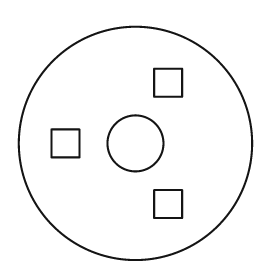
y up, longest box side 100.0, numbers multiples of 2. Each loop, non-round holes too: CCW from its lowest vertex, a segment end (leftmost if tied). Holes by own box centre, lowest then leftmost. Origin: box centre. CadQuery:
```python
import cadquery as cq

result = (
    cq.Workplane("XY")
    .moveTo(0.0, 0.0)
    .circle(50.0)
    .moveTo(8.0, -32.0)
    .lineTo(20.0, -32.0)
    .lineTo(20.0, -20.0)
    .lineTo(8.0, -20.0)
    .close()
    .moveTo(-36.0, -6.0)
    .lineTo(-24.0, -6.0)
    .lineTo(-24.0, 6.0)
    .lineTo(-36.0, 6.0)
    .close()
    .moveTo(0.0, 0.0)
    .circle(12.0)
    .moveTo(8.0, 20.0)
    .lineTo(20.0, 20.0)
    .lineTo(20.0, 32.0)
    .lineTo(8.0, 32.0)
    .close()
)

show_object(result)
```